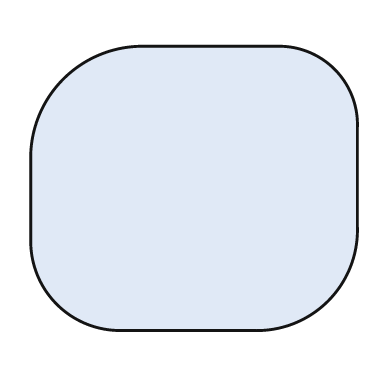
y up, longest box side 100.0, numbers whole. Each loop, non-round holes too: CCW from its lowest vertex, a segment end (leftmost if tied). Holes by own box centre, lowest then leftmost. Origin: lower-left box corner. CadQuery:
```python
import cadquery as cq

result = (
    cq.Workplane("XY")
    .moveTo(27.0, 0.0)
    .lineTo(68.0, 0.0)
    .threePointArc((91.0, 9.0), (100.0, 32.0))
    .lineTo(100.0, 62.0)
    .threePointArc((93.0, 80.0), (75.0, 87.0))
    .lineTo(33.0, 87.0)
    .threePointArc((10.0, 77.0), (0.0, 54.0))
    .lineTo(0.0, 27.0)
    .threePointArc((8.0, 8.0), (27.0, 0.0))
    .close()
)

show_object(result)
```